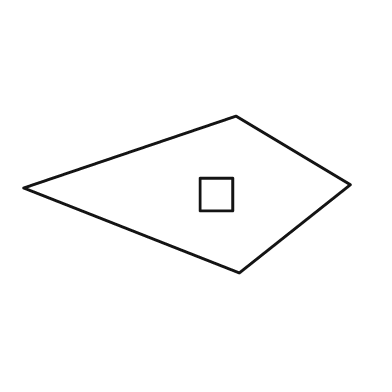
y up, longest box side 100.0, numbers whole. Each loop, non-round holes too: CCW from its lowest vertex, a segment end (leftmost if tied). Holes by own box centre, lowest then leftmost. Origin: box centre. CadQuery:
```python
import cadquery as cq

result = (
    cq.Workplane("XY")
    .moveTo(16.0, -24.0)
    .lineTo(50.0, 3.0)
    .lineTo(15.0, 24.0)
    .lineTo(-50.0, 2.0)
    .close()
    .moveTo(4.0, -5.0)
    .lineTo(14.0, -5.0)
    .lineTo(14.0, 5.0)
    .lineTo(4.0, 5.0)
    .close()
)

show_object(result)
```